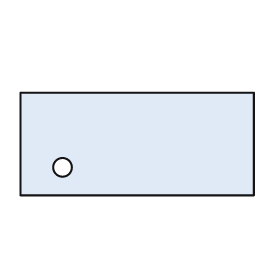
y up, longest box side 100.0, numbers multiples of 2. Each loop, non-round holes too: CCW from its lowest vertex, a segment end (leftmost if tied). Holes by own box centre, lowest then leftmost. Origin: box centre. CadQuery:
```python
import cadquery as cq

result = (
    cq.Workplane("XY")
    .moveTo(-50.0, -22.0)
    .lineTo(50.0, -22.0)
    .lineTo(50.0, 22.0)
    .lineTo(-50.0, 22.0)
    .close()
    .moveTo(-32.0, -10.0)
    .circle(4.0)
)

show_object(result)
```